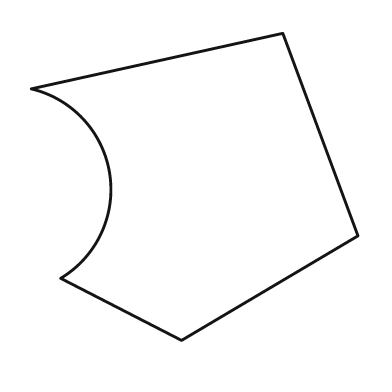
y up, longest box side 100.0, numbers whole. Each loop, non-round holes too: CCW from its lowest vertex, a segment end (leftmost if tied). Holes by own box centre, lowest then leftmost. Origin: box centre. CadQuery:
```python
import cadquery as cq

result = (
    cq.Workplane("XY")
    .moveTo(-4.0, -47.0)
    .lineTo(50.0, -15.0)
    .lineTo(27.0, 47.0)
    .lineTo(-50.0, 30.0)
    .threePointArc((-26.0, 4.0), (-41.0, -28.0))
    .close()
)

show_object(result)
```